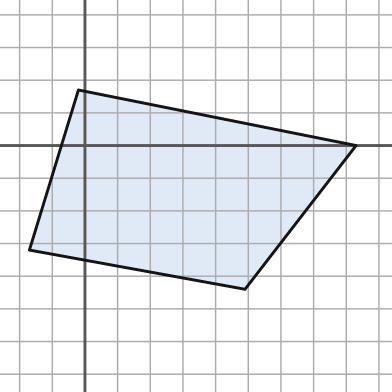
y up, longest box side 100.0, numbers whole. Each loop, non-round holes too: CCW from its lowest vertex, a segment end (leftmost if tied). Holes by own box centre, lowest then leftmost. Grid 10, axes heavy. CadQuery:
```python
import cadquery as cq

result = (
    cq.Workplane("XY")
    .moveTo(49.0, -44.0)
    .lineTo(83.0, 0.0)
    .lineTo(-2.0, 17.0)
    .lineTo(-17.0, -32.0)
    .close()
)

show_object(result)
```